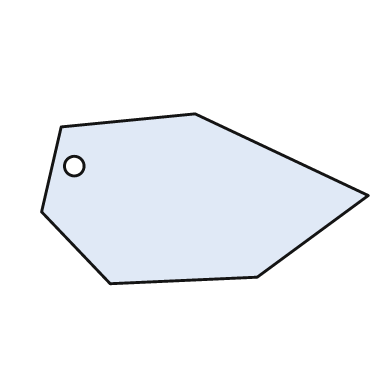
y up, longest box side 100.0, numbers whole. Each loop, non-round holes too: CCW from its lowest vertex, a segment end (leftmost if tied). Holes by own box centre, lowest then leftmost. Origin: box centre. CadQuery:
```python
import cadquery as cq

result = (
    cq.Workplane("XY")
    .moveTo(-29.0, -26.0)
    .lineTo(16.0, -24.0)
    .lineTo(50.0, 1.0)
    .lineTo(-3.0, 26.0)
    .lineTo(-44.0, 22.0)
    .lineTo(-50.0, -4.0)
    .close()
    .moveTo(-40.0, 10.0)
    .circle(3.0)
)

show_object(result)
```